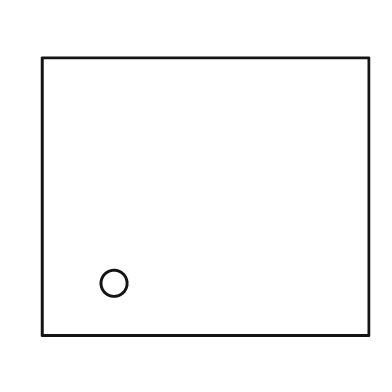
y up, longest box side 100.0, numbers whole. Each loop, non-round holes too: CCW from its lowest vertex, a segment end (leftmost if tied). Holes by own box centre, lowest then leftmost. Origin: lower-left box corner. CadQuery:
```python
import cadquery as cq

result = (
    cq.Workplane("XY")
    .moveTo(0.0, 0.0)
    .lineTo(100.0, 0.0)
    .lineTo(100.0, 85.0)
    .lineTo(0.0, 85.0)
    .close()
    .moveTo(22.0, 16.0)
    .circle(4.0)
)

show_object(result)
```